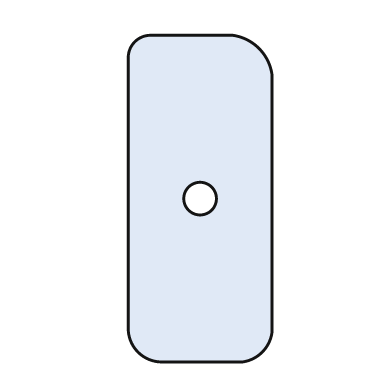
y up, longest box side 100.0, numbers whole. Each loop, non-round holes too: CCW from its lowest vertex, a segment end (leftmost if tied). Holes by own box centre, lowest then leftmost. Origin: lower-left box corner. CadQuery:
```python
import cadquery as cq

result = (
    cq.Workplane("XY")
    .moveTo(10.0, 0.0)
    .lineTo(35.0, 0.0)
    .threePointArc((41.0, 3.0), (44.0, 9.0))
    .lineTo(44.0, 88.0)
    .threePointArc((40.0, 96.0), (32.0, 100.0))
    .lineTo(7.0, 100.0)
    .threePointArc((2.0, 98.0), (0.0, 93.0))
    .lineTo(0.0, 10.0)
    .threePointArc((3.0, 3.0), (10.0, 0.0))
    .close()
    .moveTo(22.0, 50.0)
    .circle(5.0)
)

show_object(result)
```